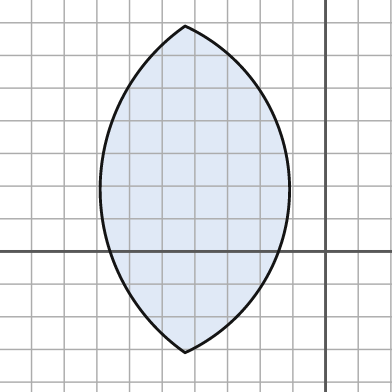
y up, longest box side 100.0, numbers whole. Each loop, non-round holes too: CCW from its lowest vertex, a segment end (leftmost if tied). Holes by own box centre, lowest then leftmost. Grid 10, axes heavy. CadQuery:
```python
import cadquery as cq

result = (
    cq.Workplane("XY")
    .moveTo(-43.0, -31.0)
    .threePointArc((-11.0, 19.0), (-43.0, 69.0))
    .threePointArc((-69.0, 19.0), (-43.0, -31.0))
    .close()
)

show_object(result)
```